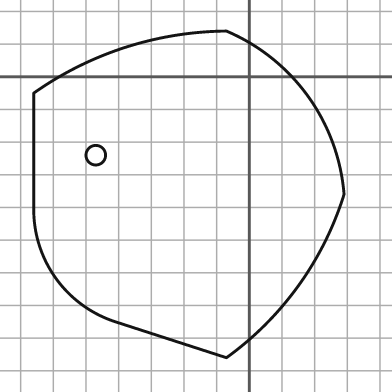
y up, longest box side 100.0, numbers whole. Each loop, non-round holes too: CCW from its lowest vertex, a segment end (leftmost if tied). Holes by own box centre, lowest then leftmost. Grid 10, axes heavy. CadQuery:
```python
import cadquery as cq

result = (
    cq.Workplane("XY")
    .moveTo(-7.0, -86.0)
    .threePointArc((15.0, -64.0), (29.0, -36.0))
    .threePointArc((18.0, -6.0), (-7.0, 14.0))
    .threePointArc((-38.0, 9.0), (-66.0, -5.0))
    .lineTo(-66.0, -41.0)
    .threePointArc((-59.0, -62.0), (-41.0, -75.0))
    .close()
    .moveTo(-47.0, -24.0)
    .circle(3.0)
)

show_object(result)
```